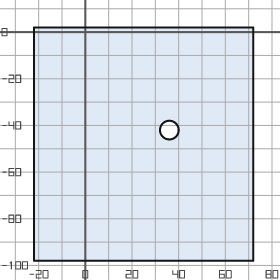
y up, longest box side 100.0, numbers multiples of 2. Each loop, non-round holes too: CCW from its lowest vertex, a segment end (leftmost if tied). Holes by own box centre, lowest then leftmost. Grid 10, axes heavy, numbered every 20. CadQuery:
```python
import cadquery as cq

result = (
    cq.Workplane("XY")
    .moveTo(-22.0, -98.0)
    .lineTo(72.0, -98.0)
    .lineTo(72.0, 2.0)
    .lineTo(-22.0, 2.0)
    .close()
    .moveTo(36.0, -42.0)
    .circle(4.0)
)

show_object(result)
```